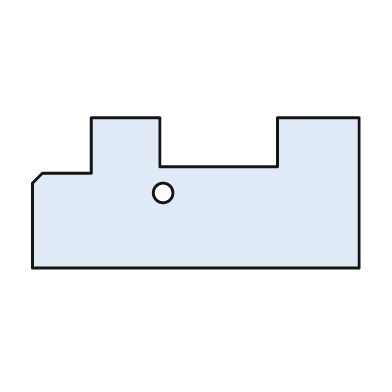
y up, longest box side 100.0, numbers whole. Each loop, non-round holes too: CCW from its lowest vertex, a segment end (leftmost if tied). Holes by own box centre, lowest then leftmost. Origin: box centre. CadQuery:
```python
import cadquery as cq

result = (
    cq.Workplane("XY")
    .moveTo(-50.0, -23.0)
    .lineTo(50.0, -23.0)
    .lineTo(50.0, 23.0)
    .lineTo(25.0, 23.0)
    .lineTo(25.0, 8.0)
    .lineTo(-11.0, 8.0)
    .lineTo(-11.0, 23.0)
    .lineTo(-32.0, 23.0)
    .lineTo(-32.0, 6.0)
    .lineTo(-47.0, 6.0)
    .lineTo(-50.0, 3.0)
    .close()
    .moveTo(-10.0, 0.0)
    .circle(3.0)
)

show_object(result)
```